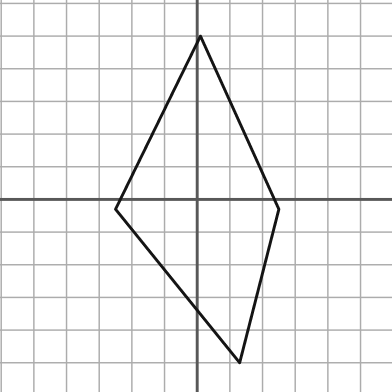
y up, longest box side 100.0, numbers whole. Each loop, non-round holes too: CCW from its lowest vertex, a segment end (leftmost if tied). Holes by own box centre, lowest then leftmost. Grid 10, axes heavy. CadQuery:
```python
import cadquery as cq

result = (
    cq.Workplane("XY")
    .moveTo(13.0, -50.0)
    .lineTo(25.0, -3.0)
    .lineTo(1.0, 50.0)
    .lineTo(-25.0, -3.0)
    .close()
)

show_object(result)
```